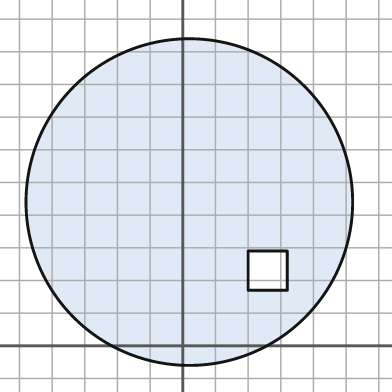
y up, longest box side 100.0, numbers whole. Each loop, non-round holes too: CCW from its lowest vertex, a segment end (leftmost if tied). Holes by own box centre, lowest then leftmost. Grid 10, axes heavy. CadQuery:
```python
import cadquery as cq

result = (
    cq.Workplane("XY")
    .moveTo(2.0, 44.0)
    .circle(50.0)
    .moveTo(20.0, 17.0)
    .lineTo(32.0, 17.0)
    .lineTo(32.0, 29.0)
    .lineTo(20.0, 29.0)
    .close()
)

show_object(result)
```